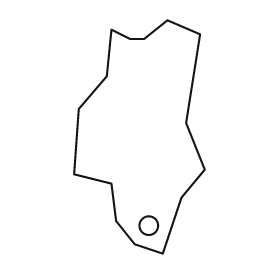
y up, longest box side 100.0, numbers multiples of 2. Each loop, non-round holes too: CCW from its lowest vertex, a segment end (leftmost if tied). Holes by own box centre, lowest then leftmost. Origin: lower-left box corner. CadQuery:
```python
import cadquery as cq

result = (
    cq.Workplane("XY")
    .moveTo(38.0, 0.0)
    .lineTo(46.0, 24.0)
    .lineTo(56.0, 36.0)
    .lineTo(48.0, 56.0)
    .lineTo(54.0, 94.0)
    .lineTo(40.0, 100.0)
    .lineTo(30.0, 92.0)
    .lineTo(24.0, 92.0)
    .lineTo(16.0, 96.0)
    .lineTo(14.0, 76.0)
    .lineTo(2.0, 62.0)
    .lineTo(0.0, 34.0)
    .lineTo(16.0, 30.0)
    .lineTo(18.0, 14.0)
    .lineTo(26.0, 4.0)
    .close()
    .moveTo(32.0, 12.0)
    .circle(4.0)
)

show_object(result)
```